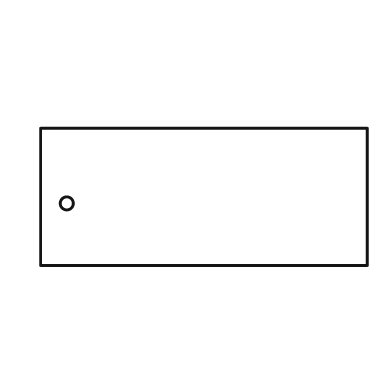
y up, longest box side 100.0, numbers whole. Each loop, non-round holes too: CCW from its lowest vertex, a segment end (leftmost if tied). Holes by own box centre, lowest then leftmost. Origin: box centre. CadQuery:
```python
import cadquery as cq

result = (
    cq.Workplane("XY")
    .moveTo(-50.0, -21.0)
    .lineTo(50.0, -21.0)
    .lineTo(50.0, 21.0)
    .lineTo(-50.0, 21.0)
    .close()
    .moveTo(-42.0, -2.0)
    .circle(2.0)
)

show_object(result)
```